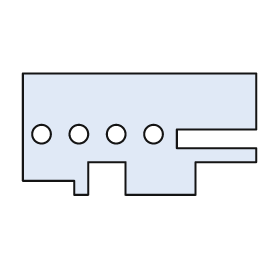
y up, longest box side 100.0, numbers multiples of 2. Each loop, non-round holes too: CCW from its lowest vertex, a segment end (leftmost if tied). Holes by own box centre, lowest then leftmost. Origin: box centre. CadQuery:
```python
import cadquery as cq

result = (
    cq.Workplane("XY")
    .moveTo(-28.0, -26.0)
    .lineTo(-22.0, -26.0)
    .lineTo(-22.0, -12.0)
    .lineTo(-6.0, -12.0)
    .lineTo(-6.0, -26.0)
    .lineTo(24.0, -26.0)
    .lineTo(24.0, -12.0)
    .lineTo(50.0, -12.0)
    .lineTo(50.0, -6.0)
    .lineTo(16.0, -6.0)
    .lineTo(16.0, 2.0)
    .lineTo(50.0, 2.0)
    .lineTo(50.0, 26.0)
    .lineTo(-50.0, 26.0)
    .lineTo(-50.0, -20.0)
    .lineTo(-28.0, -20.0)
    .close()
    .moveTo(-42.0, 0.0)
    .circle(4.0)
    .moveTo(-26.0, 0.0)
    .circle(4.0)
    .moveTo(-10.0, 0.0)
    .circle(4.0)
    .moveTo(6.0, 0.0)
    .circle(4.0)
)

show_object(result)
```